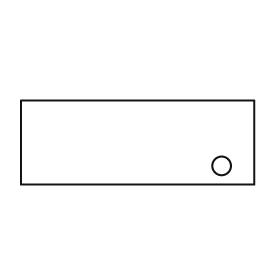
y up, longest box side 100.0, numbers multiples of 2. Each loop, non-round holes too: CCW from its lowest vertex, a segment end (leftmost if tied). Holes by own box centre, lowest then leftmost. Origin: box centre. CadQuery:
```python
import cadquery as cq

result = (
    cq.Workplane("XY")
    .moveTo(-50.0, -18.0)
    .lineTo(50.0, -18.0)
    .lineTo(50.0, 18.0)
    .lineTo(-50.0, 18.0)
    .close()
    .moveTo(36.0, -10.0)
    .circle(4.0)
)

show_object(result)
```